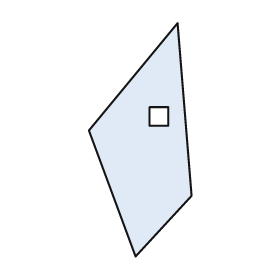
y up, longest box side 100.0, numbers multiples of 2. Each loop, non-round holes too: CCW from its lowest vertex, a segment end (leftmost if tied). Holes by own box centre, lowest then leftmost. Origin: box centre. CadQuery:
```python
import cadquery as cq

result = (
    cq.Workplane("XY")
    .moveTo(-2.0, -50.0)
    .lineTo(22.0, -24.0)
    .lineTo(16.0, 50.0)
    .lineTo(-22.0, 4.0)
    .close()
    .moveTo(4.0, 6.0)
    .lineTo(12.0, 6.0)
    .lineTo(12.0, 14.0)
    .lineTo(4.0, 14.0)
    .close()
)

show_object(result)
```